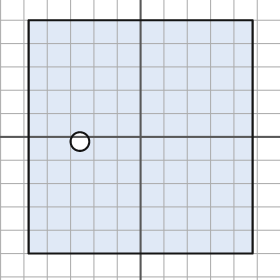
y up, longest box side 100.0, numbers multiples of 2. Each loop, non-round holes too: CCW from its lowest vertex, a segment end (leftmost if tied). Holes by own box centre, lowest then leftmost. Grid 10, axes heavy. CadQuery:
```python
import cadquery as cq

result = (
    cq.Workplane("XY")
    .moveTo(-48.0, -50.0)
    .lineTo(48.0, -50.0)
    .lineTo(48.0, 50.0)
    .lineTo(-48.0, 50.0)
    .close()
    .moveTo(-26.0, -2.0)
    .circle(4.0)
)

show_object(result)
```